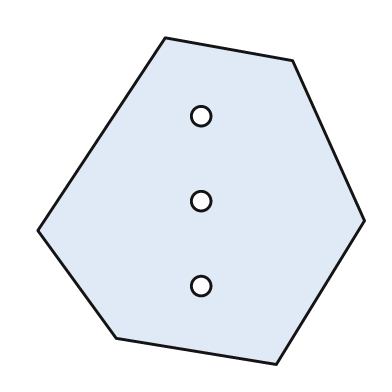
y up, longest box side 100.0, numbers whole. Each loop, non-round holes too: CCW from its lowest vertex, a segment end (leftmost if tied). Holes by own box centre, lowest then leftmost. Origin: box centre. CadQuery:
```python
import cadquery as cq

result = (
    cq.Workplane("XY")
    .moveTo(23.0, -50.0)
    .lineTo(50.0, -6.0)
    .lineTo(28.0, 43.0)
    .lineTo(-11.0, 50.0)
    .lineTo(-50.0, -9.0)
    .lineTo(-26.0, -42.0)
    .close()
    .moveTo(0.0, -26.0)
    .circle(3.0)
    .moveTo(0.0, 0.0)
    .circle(3.0)
    .moveTo(0.0, 26.0)
    .circle(3.0)
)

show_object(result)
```